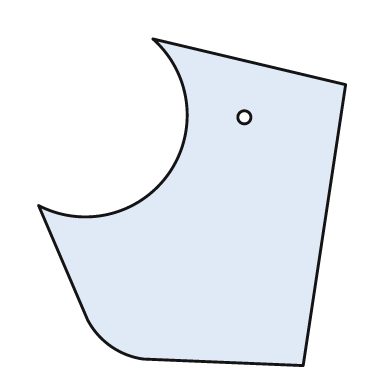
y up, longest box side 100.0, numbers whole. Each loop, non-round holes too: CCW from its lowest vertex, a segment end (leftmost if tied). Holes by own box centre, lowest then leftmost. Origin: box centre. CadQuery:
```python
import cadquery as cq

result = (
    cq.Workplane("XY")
    .moveTo(34.0, -50.0)
    .lineTo(47.0, 36.0)
    .lineTo(-12.0, 50.0)
    .threePointArc((-7.0, 9.0), (-47.0, -1.0))
    .lineTo(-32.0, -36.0)
    .threePointArc((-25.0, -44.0), (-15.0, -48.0))
    .close()
    .moveTo(16.0, 26.0)
    .circle(2.0)
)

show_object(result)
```